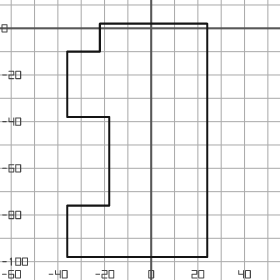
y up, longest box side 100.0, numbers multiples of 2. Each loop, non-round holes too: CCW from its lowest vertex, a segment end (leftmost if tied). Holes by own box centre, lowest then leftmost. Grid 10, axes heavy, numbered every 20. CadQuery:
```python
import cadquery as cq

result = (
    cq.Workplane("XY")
    .moveTo(-36.0, -98.0)
    .lineTo(24.0, -98.0)
    .lineTo(24.0, 2.0)
    .lineTo(-22.0, 2.0)
    .lineTo(-22.0, -10.0)
    .lineTo(-36.0, -10.0)
    .lineTo(-36.0, -38.0)
    .lineTo(-18.0, -38.0)
    .lineTo(-18.0, -76.0)
    .lineTo(-36.0, -76.0)
    .close()
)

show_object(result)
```